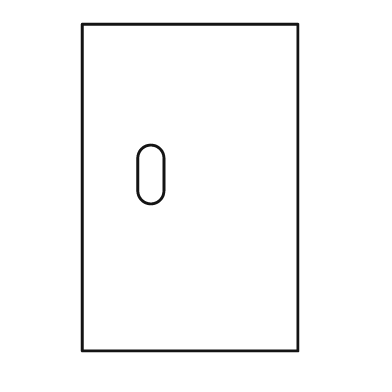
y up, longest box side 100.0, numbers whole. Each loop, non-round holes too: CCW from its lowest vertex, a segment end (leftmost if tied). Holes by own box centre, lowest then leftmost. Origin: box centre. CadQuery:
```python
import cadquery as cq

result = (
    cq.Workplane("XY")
    .moveTo(-33.0, -50.0)
    .lineTo(33.0, -50.0)
    .lineTo(33.0, 50.0)
    .lineTo(-33.0, 50.0)
    .close()
    .moveTo(-16.0, -1.0)
    .threePointArc((-12.0, -5.0), (-8.0, -1.0))
    .lineTo(-8.0, 9.0)
    .threePointArc((-12.0, 13.0), (-16.0, 9.0))
    .close()
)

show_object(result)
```